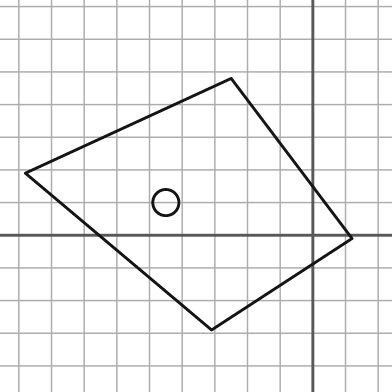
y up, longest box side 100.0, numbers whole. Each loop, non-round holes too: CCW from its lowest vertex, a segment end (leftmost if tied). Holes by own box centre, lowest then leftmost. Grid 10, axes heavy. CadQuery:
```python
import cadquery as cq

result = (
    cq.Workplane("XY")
    .moveTo(-31.0, -29.0)
    .lineTo(12.0, -1.0)
    .lineTo(-25.0, 48.0)
    .lineTo(-88.0, 19.0)
    .close()
    .moveTo(-45.0, 10.0)
    .circle(4.0)
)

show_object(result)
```